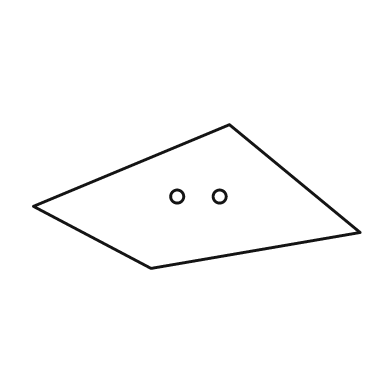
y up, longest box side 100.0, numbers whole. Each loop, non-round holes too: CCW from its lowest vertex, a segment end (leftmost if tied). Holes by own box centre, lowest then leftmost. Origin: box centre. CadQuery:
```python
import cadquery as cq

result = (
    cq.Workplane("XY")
    .moveTo(-14.0, -22.0)
    .lineTo(50.0, -11.0)
    .lineTo(10.0, 22.0)
    .lineTo(-50.0, -3.0)
    .close()
    .moveTo(-6.0, 0.0)
    .circle(2.0)
    .moveTo(7.0, 0.0)
    .circle(2.0)
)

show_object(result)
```